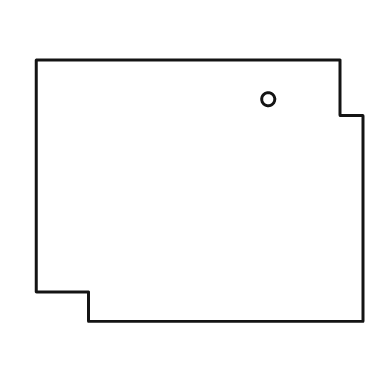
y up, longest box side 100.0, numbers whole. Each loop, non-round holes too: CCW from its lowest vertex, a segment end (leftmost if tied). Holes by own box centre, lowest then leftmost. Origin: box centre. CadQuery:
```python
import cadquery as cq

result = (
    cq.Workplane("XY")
    .moveTo(-34.0, -40.0)
    .lineTo(50.0, -40.0)
    .lineTo(50.0, 23.0)
    .lineTo(43.0, 23.0)
    .lineTo(43.0, 40.0)
    .lineTo(-50.0, 40.0)
    .lineTo(-50.0, -31.0)
    .lineTo(-34.0, -31.0)
    .close()
    .moveTo(21.0, 28.0)
    .circle(2.0)
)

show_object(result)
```